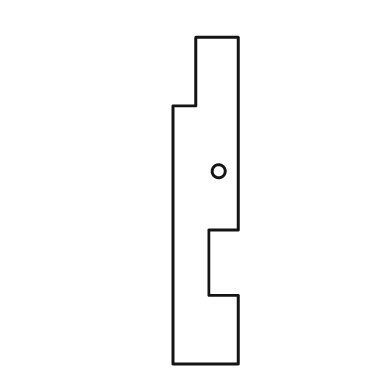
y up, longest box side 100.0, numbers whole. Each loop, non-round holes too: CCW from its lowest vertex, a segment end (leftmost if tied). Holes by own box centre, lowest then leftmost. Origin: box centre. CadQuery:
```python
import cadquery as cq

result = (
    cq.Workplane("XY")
    .moveTo(-10.0, -50.0)
    .lineTo(10.0, -50.0)
    .lineTo(10.0, -29.0)
    .lineTo(1.0, -29.0)
    .lineTo(1.0, -9.0)
    .lineTo(10.0, -9.0)
    .lineTo(10.0, 50.0)
    .lineTo(-3.0, 50.0)
    .lineTo(-3.0, 29.0)
    .lineTo(-10.0, 29.0)
    .close()
    .moveTo(4.0, 9.0)
    .circle(2.0)
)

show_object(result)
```